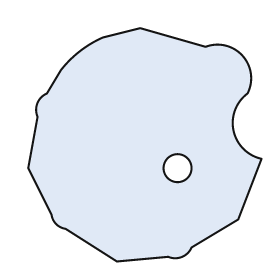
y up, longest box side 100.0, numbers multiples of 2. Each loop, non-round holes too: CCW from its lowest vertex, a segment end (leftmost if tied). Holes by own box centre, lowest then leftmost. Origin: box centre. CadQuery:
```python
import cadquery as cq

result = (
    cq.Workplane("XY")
    .moveTo(-12.0, -50.0)
    .lineTo(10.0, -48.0)
    .threePointArc((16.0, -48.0), (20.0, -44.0))
    .lineTo(40.0, -32.0)
    .lineTo(50.0, -6.0)
    .threePointArc((38.0, 6.0), (44.0, 22.0))
    .threePointArc((42.0, 38.0), (26.0, 42.0))
    .lineTo(-2.0, 50.0)
    .lineTo(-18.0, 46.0)
    .threePointArc((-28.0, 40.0), (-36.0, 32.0))
    .lineTo(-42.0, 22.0)
    .threePointArc((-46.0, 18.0), (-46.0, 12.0))
    .lineTo(-50.0, -10.0)
    .lineTo(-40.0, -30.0)
    .threePointArc((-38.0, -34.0), (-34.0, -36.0))
    .close()
    .moveTo(14.0, -10.0)
    .circle(6.0)
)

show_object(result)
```